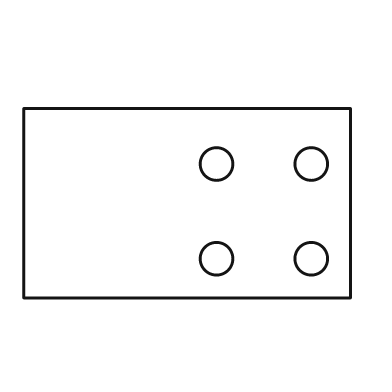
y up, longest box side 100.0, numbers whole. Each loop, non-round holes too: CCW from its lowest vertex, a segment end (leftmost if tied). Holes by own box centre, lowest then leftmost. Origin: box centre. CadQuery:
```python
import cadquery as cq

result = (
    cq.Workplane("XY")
    .moveTo(-50.0, -29.0)
    .lineTo(50.0, -29.0)
    .lineTo(50.0, 29.0)
    .lineTo(-50.0, 29.0)
    .close()
    .moveTo(9.0, -17.0)
    .circle(5.0)
    .moveTo(38.0, -17.0)
    .circle(5.0)
    .moveTo(9.0, 12.0)
    .circle(5.0)
    .moveTo(38.0, 12.0)
    .circle(5.0)
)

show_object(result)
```